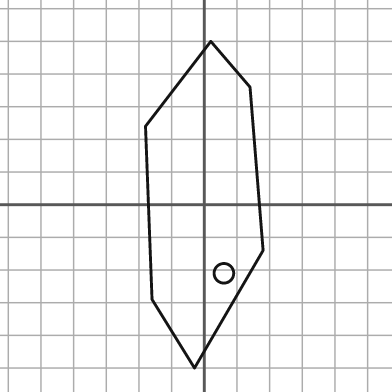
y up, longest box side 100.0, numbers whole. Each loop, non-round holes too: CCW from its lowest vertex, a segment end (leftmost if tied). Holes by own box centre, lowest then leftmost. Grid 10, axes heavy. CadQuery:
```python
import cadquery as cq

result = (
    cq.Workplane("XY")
    .moveTo(-3.0, -50.0)
    .lineTo(18.0, -14.0)
    .lineTo(14.0, 36.0)
    .lineTo(2.0, 50.0)
    .lineTo(-18.0, 24.0)
    .lineTo(-16.0, -29.0)
    .close()
    .moveTo(6.0, -21.0)
    .circle(3.0)
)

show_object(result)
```